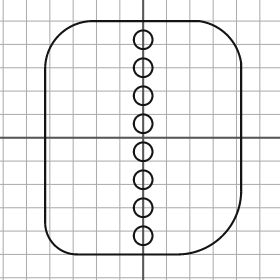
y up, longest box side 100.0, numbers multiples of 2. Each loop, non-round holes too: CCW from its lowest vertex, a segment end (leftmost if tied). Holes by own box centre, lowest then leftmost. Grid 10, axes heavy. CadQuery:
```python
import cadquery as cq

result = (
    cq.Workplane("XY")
    .moveTo(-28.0, -50.0)
    .lineTo(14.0, -50.0)
    .threePointArc((34.0, -42.0), (42.0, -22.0))
    .lineTo(42.0, 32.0)
    .threePointArc((36.0, 44.0), (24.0, 50.0))
    .lineTo(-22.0, 50.0)
    .threePointArc((-36.0, 44.0), (-42.0, 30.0))
    .lineTo(-42.0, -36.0)
    .threePointArc((-38.0, -46.0), (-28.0, -50.0))
    .close()
    .moveTo(0.0, -42.0)
    .circle(4.0)
    .moveTo(0.0, -30.0)
    .circle(4.0)
    .moveTo(0.0, -18.0)
    .circle(4.0)
    .moveTo(0.0, -6.0)
    .circle(4.0)
    .moveTo(0.0, 6.0)
    .circle(4.0)
    .moveTo(0.0, 18.0)
    .circle(4.0)
    .moveTo(0.0, 30.0)
    .circle(4.0)
    .moveTo(0.0, 42.0)
    .circle(4.0)
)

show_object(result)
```